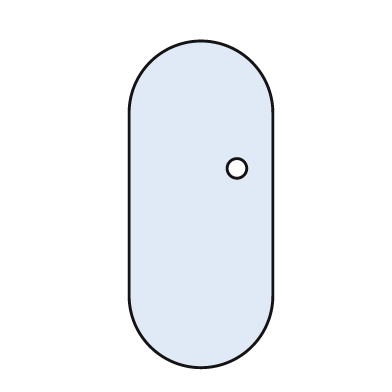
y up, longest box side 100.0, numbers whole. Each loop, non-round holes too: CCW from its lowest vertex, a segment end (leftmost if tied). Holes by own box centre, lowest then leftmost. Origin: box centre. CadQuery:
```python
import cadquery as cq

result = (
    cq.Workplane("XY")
    .moveTo(-22.0, -28.0)
    .threePointArc((0.0, -50.0), (22.0, -28.0))
    .lineTo(22.0, 28.0)
    .threePointArc((0.0, 50.0), (-22.0, 28.0))
    .close()
    .moveTo(11.0, 11.0)
    .circle(3.0)
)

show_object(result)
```